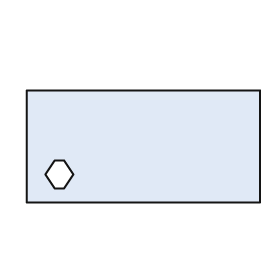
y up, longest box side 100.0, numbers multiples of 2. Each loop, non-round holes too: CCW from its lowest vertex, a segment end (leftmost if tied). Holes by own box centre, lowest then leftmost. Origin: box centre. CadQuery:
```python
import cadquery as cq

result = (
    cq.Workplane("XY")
    .moveTo(-50.0, -24.0)
    .lineTo(50.0, -24.0)
    .lineTo(50.0, 24.0)
    .lineTo(-50.0, 24.0)
    .close()
    .moveTo(-38.0, -18.0)
    .lineTo(-34.0, -18.0)
    .lineTo(-30.0, -12.0)
    .lineTo(-34.0, -6.0)
    .lineTo(-38.0, -6.0)
    .lineTo(-42.0, -12.0)
    .close()
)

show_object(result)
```